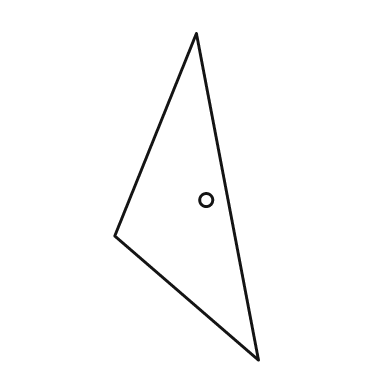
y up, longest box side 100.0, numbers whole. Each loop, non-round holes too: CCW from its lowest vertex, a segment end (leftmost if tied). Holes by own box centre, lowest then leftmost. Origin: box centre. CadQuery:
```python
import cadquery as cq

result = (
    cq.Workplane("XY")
    .moveTo(22.0, -50.0)
    .lineTo(3.0, 50.0)
    .lineTo(-22.0, -12.0)
    .close()
    .moveTo(6.0, -1.0)
    .circle(2.0)
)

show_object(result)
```